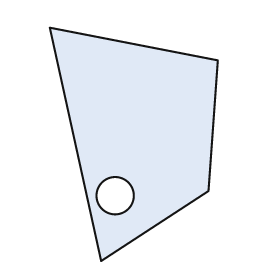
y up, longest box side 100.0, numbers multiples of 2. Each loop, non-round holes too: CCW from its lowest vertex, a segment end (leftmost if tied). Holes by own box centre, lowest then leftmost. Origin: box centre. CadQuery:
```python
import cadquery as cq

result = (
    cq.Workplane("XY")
    .moveTo(-14.0, -50.0)
    .lineTo(32.0, -20.0)
    .lineTo(36.0, 36.0)
    .lineTo(-36.0, 50.0)
    .close()
    .moveTo(-8.0, -22.0)
    .circle(8.0)
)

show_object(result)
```